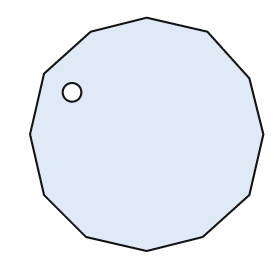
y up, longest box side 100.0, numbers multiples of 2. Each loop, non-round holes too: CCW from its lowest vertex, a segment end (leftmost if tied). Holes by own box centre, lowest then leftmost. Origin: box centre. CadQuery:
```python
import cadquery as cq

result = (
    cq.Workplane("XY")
    .moveTo(0.0, -50.0)
    .lineTo(24.0, -44.0)
    .lineTo(44.0, -26.0)
    .lineTo(50.0, 0.0)
    .lineTo(44.0, 24.0)
    .lineTo(26.0, 44.0)
    .lineTo(0.0, 50.0)
    .lineTo(-24.0, 44.0)
    .lineTo(-44.0, 26.0)
    .lineTo(-50.0, 0.0)
    .lineTo(-44.0, -26.0)
    .lineTo(-26.0, -44.0)
    .close()
    .moveTo(-32.0, 18.0)
    .circle(4.0)
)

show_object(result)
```